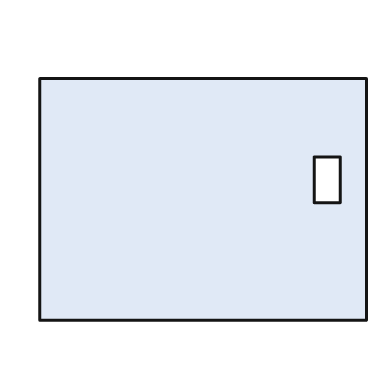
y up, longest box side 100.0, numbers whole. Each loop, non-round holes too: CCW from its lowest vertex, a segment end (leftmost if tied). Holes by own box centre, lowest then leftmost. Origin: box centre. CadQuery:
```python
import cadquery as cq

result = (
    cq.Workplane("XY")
    .moveTo(-50.0, -37.0)
    .lineTo(50.0, -37.0)
    .lineTo(50.0, 37.0)
    .lineTo(-50.0, 37.0)
    .close()
    .moveTo(34.0, -1.0)
    .lineTo(42.0, -1.0)
    .lineTo(42.0, 13.0)
    .lineTo(34.0, 13.0)
    .close()
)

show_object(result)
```